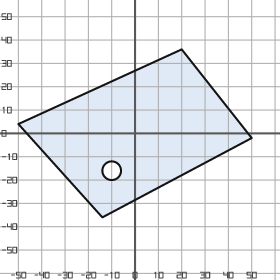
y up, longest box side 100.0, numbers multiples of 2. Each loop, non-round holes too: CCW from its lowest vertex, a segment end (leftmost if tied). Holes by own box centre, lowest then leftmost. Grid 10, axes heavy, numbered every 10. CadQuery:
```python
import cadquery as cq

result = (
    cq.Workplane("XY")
    .moveTo(-14.0, -36.0)
    .lineTo(50.0, -2.0)
    .lineTo(20.0, 36.0)
    .lineTo(-50.0, 4.0)
    .close()
    .moveTo(-10.0, -16.0)
    .circle(4.0)
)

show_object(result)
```